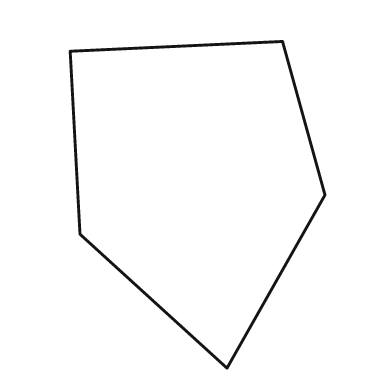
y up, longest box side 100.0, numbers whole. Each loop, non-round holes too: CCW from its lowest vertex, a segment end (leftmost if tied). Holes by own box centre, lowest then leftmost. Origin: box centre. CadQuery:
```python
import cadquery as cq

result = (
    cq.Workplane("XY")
    .moveTo(9.0, -50.0)
    .lineTo(39.0, 3.0)
    .lineTo(26.0, 50.0)
    .lineTo(-39.0, 47.0)
    .lineTo(-36.0, -9.0)
    .close()
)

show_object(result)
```